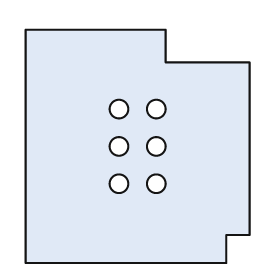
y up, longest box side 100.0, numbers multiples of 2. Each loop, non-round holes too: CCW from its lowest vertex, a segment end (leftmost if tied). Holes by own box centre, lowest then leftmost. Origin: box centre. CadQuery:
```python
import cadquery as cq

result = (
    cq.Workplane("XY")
    .moveTo(-48.0, -50.0)
    .lineTo(38.0, -50.0)
    .lineTo(38.0, -38.0)
    .lineTo(48.0, -38.0)
    .lineTo(48.0, 36.0)
    .lineTo(12.0, 36.0)
    .lineTo(12.0, 50.0)
    .lineTo(-48.0, 50.0)
    .close()
    .moveTo(-8.0, -16.0)
    .circle(4.0)
    .moveTo(8.0, -16.0)
    .circle(4.0)
    .moveTo(-8.0, 0.0)
    .circle(4.0)
    .moveTo(8.0, 0.0)
    .circle(4.0)
    .moveTo(-8.0, 16.0)
    .circle(4.0)
    .moveTo(8.0, 16.0)
    .circle(4.0)
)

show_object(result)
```